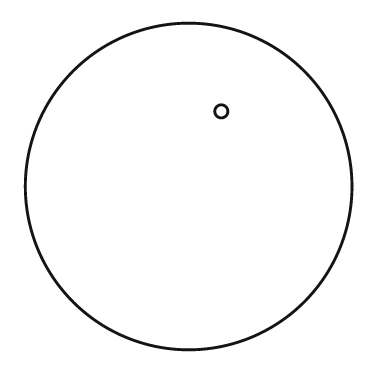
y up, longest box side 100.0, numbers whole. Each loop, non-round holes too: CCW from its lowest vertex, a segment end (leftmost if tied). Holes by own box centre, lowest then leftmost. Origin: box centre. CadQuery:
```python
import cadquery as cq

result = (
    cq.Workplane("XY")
    .moveTo(0.0, 0.0)
    .circle(50.0)
    .moveTo(10.0, 23.0)
    .circle(2.0)
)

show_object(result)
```